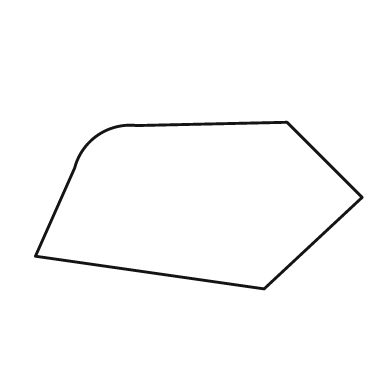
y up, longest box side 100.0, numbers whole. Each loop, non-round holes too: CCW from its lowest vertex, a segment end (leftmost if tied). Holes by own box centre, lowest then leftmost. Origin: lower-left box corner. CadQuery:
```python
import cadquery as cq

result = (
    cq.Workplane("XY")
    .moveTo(70.0, 0.0)
    .lineTo(100.0, 28.0)
    .lineTo(77.0, 51.0)
    .lineTo(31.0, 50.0)
    .threePointArc((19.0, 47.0), (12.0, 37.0))
    .lineTo(0.0, 10.0)
    .close()
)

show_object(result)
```